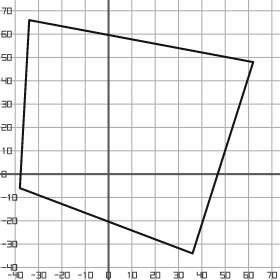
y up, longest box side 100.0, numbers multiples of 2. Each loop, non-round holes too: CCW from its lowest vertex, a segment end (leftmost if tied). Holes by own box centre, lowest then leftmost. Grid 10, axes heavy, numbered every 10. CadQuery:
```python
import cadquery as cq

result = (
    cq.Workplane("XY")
    .moveTo(36.0, -34.0)
    .lineTo(62.0, 48.0)
    .lineTo(-34.0, 66.0)
    .lineTo(-38.0, -6.0)
    .close()
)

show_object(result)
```